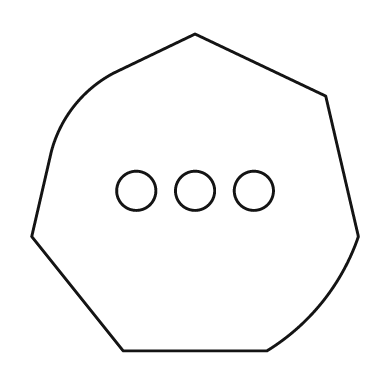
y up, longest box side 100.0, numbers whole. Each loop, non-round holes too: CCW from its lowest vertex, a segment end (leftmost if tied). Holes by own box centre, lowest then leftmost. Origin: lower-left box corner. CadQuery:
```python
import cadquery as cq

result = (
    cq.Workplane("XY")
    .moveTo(28.0, 0.0)
    .lineTo(72.0, 0.0)
    .threePointArc((89.0, 15.0), (100.0, 35.0))
    .lineTo(90.0, 78.0)
    .lineTo(50.0, 97.0)
    .lineTo(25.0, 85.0)
    .threePointArc((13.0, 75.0), (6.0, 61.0))
    .lineTo(0.0, 35.0)
    .close()
    .moveTo(32.0, 49.0)
    .circle(6.0)
    .moveTo(50.0, 49.0)
    .circle(6.0)
    .moveTo(68.0, 49.0)
    .circle(6.0)
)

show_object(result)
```